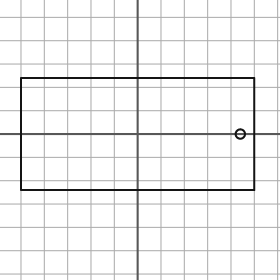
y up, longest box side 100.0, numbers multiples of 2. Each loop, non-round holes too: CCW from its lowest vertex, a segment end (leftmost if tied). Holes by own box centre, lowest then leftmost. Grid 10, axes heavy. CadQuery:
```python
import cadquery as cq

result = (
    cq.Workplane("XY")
    .moveTo(-50.0, -24.0)
    .lineTo(50.0, -24.0)
    .lineTo(50.0, 24.0)
    .lineTo(-50.0, 24.0)
    .close()
    .moveTo(44.0, 0.0)
    .circle(2.0)
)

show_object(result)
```